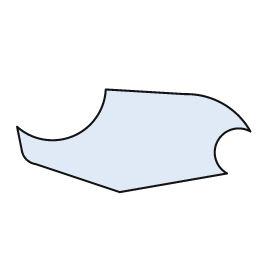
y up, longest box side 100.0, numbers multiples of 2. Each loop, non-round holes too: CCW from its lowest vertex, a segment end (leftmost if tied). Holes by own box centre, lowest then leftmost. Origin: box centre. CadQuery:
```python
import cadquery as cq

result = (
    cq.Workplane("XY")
    .moveTo(-6.0, -22.0)
    .lineTo(40.0, -14.0)
    .threePointArc((36.0, 0.0), (50.0, 4.0))
    .threePointArc((38.0, 16.0), (22.0, 20.0))
    .lineTo(-12.0, 22.0)
    .threePointArc((-26.0, 2.0), (-50.0, 6.0))
    .lineTo(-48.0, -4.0)
    .threePointArc((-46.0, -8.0), (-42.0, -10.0))
    .close()
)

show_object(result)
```